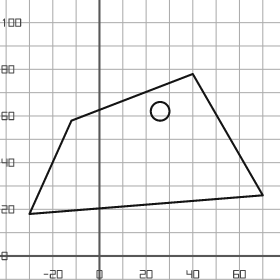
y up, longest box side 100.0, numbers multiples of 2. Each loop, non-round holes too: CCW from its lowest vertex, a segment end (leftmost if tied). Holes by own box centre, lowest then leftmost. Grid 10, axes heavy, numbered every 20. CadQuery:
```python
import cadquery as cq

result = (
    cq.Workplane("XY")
    .moveTo(-30.0, 18.0)
    .lineTo(70.0, 26.0)
    .lineTo(40.0, 78.0)
    .lineTo(-12.0, 58.0)
    .close()
    .moveTo(26.0, 62.0)
    .circle(4.0)
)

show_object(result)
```